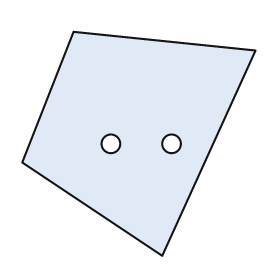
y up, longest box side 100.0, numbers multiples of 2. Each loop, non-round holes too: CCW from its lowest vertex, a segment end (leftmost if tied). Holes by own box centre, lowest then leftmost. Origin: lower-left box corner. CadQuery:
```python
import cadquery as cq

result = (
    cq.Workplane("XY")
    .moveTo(60.0, 0.0)
    .lineTo(100.0, 88.0)
    .lineTo(22.0, 96.0)
    .lineTo(0.0, 40.0)
    .close()
    .moveTo(38.0, 48.0)
    .circle(4.0)
    .moveTo(64.0, 48.0)
    .circle(4.0)
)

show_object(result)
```